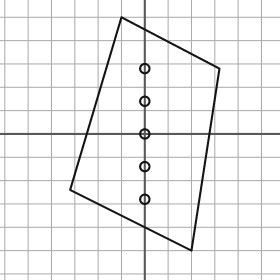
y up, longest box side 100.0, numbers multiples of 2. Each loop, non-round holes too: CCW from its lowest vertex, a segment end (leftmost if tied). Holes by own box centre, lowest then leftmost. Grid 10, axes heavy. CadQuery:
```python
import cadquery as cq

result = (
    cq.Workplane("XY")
    .moveTo(20.0, -50.0)
    .lineTo(32.0, 28.0)
    .lineTo(-10.0, 50.0)
    .lineTo(-32.0, -24.0)
    .close()
    .moveTo(0.0, -28.0)
    .circle(2.0)
    .moveTo(0.0, -14.0)
    .circle(2.0)
    .moveTo(0.0, 0.0)
    .circle(2.0)
    .moveTo(0.0, 14.0)
    .circle(2.0)
    .moveTo(0.0, 28.0)
    .circle(2.0)
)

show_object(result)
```